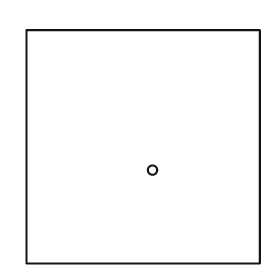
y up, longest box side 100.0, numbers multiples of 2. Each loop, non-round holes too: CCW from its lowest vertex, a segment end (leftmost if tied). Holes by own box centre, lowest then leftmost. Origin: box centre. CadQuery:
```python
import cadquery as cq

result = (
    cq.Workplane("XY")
    .moveTo(-50.0, -50.0)
    .lineTo(50.0, -50.0)
    .lineTo(50.0, 50.0)
    .lineTo(-50.0, 50.0)
    .close()
    .moveTo(4.0, -10.0)
    .circle(2.0)
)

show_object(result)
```